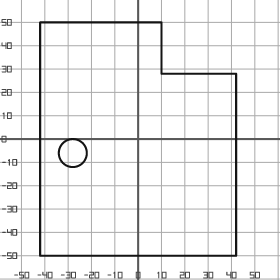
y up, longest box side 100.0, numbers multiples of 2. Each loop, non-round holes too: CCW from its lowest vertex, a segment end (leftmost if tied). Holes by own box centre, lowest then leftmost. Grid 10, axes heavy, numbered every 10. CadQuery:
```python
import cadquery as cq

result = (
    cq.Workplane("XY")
    .moveTo(-42.0, -50.0)
    .lineTo(42.0, -50.0)
    .lineTo(42.0, 28.0)
    .lineTo(10.0, 28.0)
    .lineTo(10.0, 50.0)
    .lineTo(-42.0, 50.0)
    .close()
    .moveTo(-28.0, -6.0)
    .circle(6.0)
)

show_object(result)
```